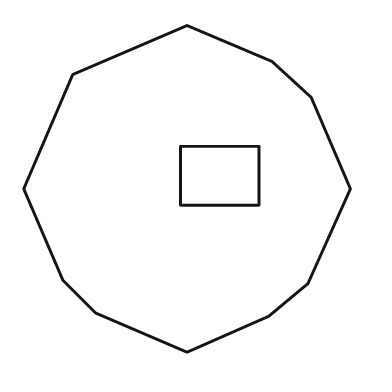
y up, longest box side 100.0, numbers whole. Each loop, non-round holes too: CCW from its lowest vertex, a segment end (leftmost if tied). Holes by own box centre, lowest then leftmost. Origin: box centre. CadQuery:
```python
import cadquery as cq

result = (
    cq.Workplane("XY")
    .moveTo(0.0, -50.0)
    .lineTo(25.0, -39.0)
    .lineTo(37.0, -29.0)
    .lineTo(50.0, 0.0)
    .lineTo(38.0, 28.0)
    .lineTo(26.0, 39.0)
    .lineTo(0.0, 50.0)
    .lineTo(-35.0, 35.0)
    .lineTo(-50.0, 0.0)
    .lineTo(-38.0, -28.0)
    .lineTo(-28.0, -38.0)
    .close()
    .moveTo(-2.0, -5.0)
    .lineTo(22.0, -5.0)
    .lineTo(22.0, 13.0)
    .lineTo(-2.0, 13.0)
    .close()
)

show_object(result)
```